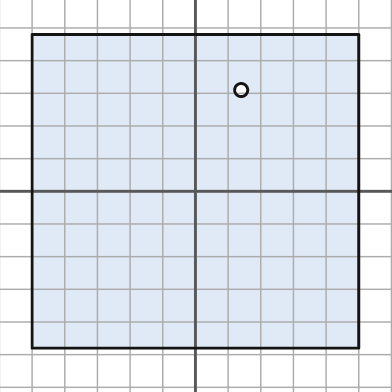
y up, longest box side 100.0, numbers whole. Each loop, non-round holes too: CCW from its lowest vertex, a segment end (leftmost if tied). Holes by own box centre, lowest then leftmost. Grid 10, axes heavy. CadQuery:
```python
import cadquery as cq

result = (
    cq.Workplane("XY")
    .moveTo(-50.0, -48.0)
    .lineTo(50.0, -48.0)
    .lineTo(50.0, 48.0)
    .lineTo(-50.0, 48.0)
    .close()
    .moveTo(14.0, 31.0)
    .circle(2.0)
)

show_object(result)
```